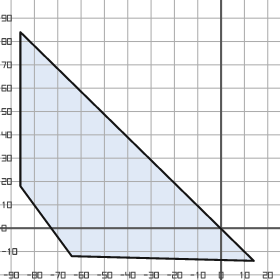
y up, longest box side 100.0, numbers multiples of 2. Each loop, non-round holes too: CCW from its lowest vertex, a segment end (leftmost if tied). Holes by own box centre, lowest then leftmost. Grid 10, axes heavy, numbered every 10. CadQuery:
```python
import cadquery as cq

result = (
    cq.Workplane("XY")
    .moveTo(14.0, -14.0)
    .lineTo(-86.0, 84.0)
    .lineTo(-86.0, 18.0)
    .lineTo(-64.0, -12.0)
    .close()
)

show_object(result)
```